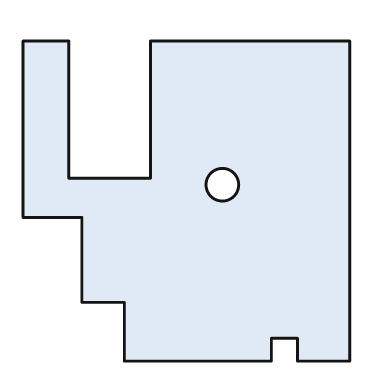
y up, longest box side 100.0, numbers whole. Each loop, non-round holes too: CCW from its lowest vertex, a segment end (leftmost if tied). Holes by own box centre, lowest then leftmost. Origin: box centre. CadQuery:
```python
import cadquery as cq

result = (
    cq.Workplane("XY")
    .moveTo(-19.0, -49.0)
    .lineTo(26.0, -49.0)
    .lineTo(26.0, -42.0)
    .lineTo(34.0, -42.0)
    .lineTo(34.0, -49.0)
    .lineTo(50.0, -49.0)
    .lineTo(50.0, 49.0)
    .lineTo(-11.0, 49.0)
    .lineTo(-11.0, 7.0)
    .lineTo(-36.0, 7.0)
    .lineTo(-36.0, 49.0)
    .lineTo(-50.0, 49.0)
    .lineTo(-50.0, -5.0)
    .lineTo(-32.0, -5.0)
    .lineTo(-32.0, -31.0)
    .lineTo(-19.0, -31.0)
    .close()
    .moveTo(11.0, 5.0)
    .circle(5.0)
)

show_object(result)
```